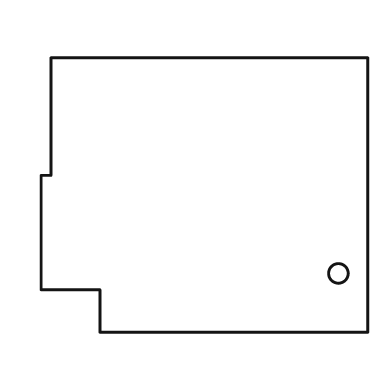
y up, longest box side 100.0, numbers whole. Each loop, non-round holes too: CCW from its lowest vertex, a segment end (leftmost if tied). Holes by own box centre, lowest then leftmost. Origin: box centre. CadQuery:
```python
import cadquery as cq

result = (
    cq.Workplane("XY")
    .moveTo(-32.0, -42.0)
    .lineTo(50.0, -42.0)
    .lineTo(50.0, 42.0)
    .lineTo(-47.0, 42.0)
    .lineTo(-47.0, 6.0)
    .lineTo(-50.0, 6.0)
    .lineTo(-50.0, -29.0)
    .lineTo(-32.0, -29.0)
    .close()
    .moveTo(41.0, -24.0)
    .circle(3.0)
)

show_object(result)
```